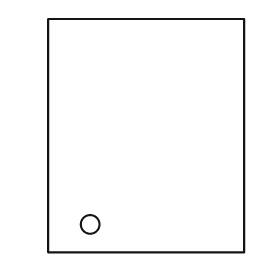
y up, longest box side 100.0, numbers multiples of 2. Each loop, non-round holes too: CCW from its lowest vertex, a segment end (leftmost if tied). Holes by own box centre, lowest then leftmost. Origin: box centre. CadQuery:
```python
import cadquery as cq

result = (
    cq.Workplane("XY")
    .moveTo(-42.0, -50.0)
    .lineTo(42.0, -50.0)
    .lineTo(42.0, 50.0)
    .lineTo(-42.0, 50.0)
    .close()
    .moveTo(-24.0, -38.0)
    .circle(4.0)
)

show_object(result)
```